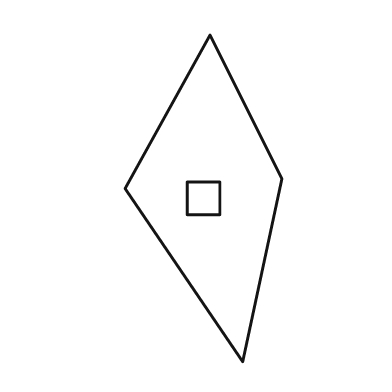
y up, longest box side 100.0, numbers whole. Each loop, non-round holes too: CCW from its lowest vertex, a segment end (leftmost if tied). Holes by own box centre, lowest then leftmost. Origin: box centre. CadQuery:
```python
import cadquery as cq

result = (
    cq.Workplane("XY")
    .moveTo(12.0, -50.0)
    .lineTo(24.0, 6.0)
    .lineTo(2.0, 50.0)
    .lineTo(-24.0, 3.0)
    .close()
    .moveTo(-5.0, -5.0)
    .lineTo(5.0, -5.0)
    .lineTo(5.0, 5.0)
    .lineTo(-5.0, 5.0)
    .close()
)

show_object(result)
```